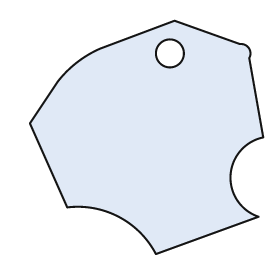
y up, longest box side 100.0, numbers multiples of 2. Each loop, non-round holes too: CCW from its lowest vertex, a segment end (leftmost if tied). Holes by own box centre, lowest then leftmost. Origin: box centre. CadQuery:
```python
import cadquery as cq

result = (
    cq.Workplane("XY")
    .moveTo(4.0, -50.0)
    .lineTo(48.0, -34.0)
    .threePointArc((36.0, -16.0), (50.0, 0.0))
    .lineTo(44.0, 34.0)
    .threePointArc((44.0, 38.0), (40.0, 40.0))
    .lineTo(12.0, 50.0)
    .lineTo(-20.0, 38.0)
    .threePointArc((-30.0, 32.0), (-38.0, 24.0))
    .lineTo(-50.0, 6.0)
    .lineTo(-34.0, -30.0)
    .threePointArc((-12.0, -34.0), (4.0, -50.0))
    .close()
    .moveTo(10.0, 36.0)
    .circle(6.0)
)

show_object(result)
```